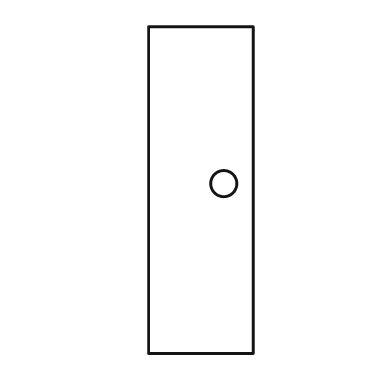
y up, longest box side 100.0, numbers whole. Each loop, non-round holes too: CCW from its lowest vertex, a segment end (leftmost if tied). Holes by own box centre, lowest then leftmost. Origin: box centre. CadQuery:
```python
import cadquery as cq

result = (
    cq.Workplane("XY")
    .moveTo(-16.0, -50.0)
    .lineTo(16.0, -50.0)
    .lineTo(16.0, 50.0)
    .lineTo(-16.0, 50.0)
    .close()
    .moveTo(7.0, 2.0)
    .circle(4.0)
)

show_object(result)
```